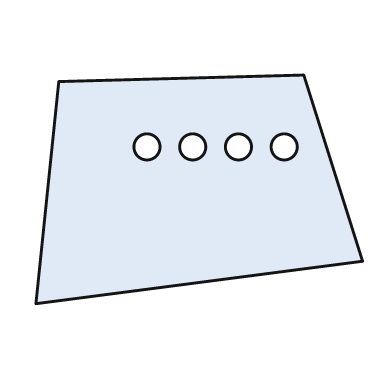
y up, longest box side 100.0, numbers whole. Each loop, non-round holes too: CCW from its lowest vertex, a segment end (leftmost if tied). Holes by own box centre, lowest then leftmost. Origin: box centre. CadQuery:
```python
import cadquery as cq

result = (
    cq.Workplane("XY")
    .moveTo(-50.0, -35.0)
    .lineTo(50.0, -22.0)
    .lineTo(32.0, 35.0)
    .lineTo(-43.0, 33.0)
    .close()
    .moveTo(-16.0, 13.0)
    .circle(4.0)
    .moveTo(-2.0, 13.0)
    .circle(4.0)
    .moveTo(12.0, 13.0)
    .circle(4.0)
    .moveTo(26.0, 13.0)
    .circle(4.0)
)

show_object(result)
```